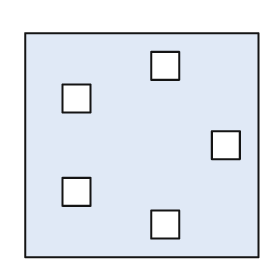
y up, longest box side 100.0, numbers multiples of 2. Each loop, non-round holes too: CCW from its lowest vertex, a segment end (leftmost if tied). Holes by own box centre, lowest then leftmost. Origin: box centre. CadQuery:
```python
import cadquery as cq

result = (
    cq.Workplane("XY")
    .moveTo(-50.0, -48.0)
    .lineTo(50.0, -48.0)
    .lineTo(50.0, 48.0)
    .lineTo(-50.0, 48.0)
    .close()
    .moveTo(4.0, -40.0)
    .lineTo(16.0, -40.0)
    .lineTo(16.0, -28.0)
    .lineTo(4.0, -28.0)
    .close()
    .moveTo(-34.0, -26.0)
    .lineTo(-22.0, -26.0)
    .lineTo(-22.0, -14.0)
    .lineTo(-34.0, -14.0)
    .close()
    .moveTo(30.0, -6.0)
    .lineTo(42.0, -6.0)
    .lineTo(42.0, 6.0)
    .lineTo(30.0, 6.0)
    .close()
    .moveTo(-34.0, 14.0)
    .lineTo(-22.0, 14.0)
    .lineTo(-22.0, 26.0)
    .lineTo(-34.0, 26.0)
    .close()
    .moveTo(4.0, 28.0)
    .lineTo(16.0, 28.0)
    .lineTo(16.0, 40.0)
    .lineTo(4.0, 40.0)
    .close()
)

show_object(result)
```